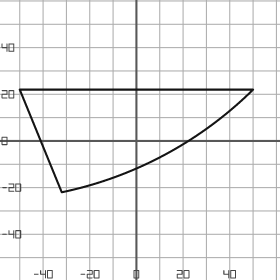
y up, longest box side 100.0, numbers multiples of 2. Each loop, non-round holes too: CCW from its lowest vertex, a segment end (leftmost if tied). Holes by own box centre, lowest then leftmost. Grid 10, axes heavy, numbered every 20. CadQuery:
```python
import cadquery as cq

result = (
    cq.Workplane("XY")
    .moveTo(-32.0, -22.0)
    .threePointArc((12.0, -6.0), (50.0, 22.0))
    .lineTo(-50.0, 22.0)
    .close()
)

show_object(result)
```